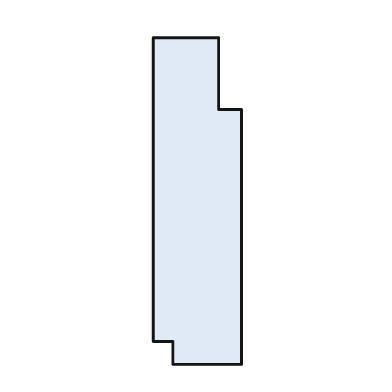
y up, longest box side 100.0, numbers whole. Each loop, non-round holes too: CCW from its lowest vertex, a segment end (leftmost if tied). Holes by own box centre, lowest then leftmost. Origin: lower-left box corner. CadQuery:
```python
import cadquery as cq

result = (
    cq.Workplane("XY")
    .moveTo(6.0, 0.0)
    .lineTo(27.0, 0.0)
    .lineTo(27.0, 78.0)
    .lineTo(20.0, 78.0)
    .lineTo(20.0, 100.0)
    .lineTo(0.0, 100.0)
    .lineTo(0.0, 7.0)
    .lineTo(6.0, 7.0)
    .close()
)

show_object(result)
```